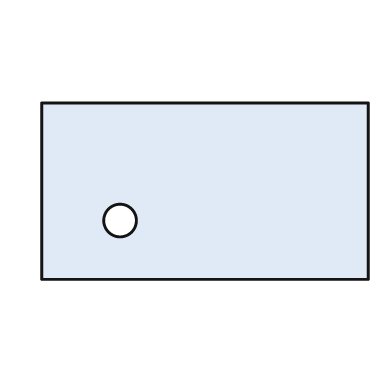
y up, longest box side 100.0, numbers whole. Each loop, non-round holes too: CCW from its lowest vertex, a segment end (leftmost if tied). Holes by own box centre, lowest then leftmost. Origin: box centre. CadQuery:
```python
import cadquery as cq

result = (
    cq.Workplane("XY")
    .moveTo(-50.0, -27.0)
    .lineTo(50.0, -27.0)
    .lineTo(50.0, 27.0)
    .lineTo(-50.0, 27.0)
    .close()
    .moveTo(-26.0, -9.0)
    .circle(5.0)
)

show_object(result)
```